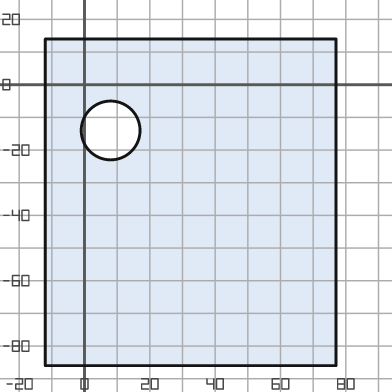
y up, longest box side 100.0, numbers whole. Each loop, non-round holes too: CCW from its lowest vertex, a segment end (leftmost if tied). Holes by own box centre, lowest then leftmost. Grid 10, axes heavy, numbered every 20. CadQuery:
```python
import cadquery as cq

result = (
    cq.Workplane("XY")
    .moveTo(-12.0, -86.0)
    .lineTo(77.0, -86.0)
    .lineTo(77.0, 14.0)
    .lineTo(-12.0, 14.0)
    .close()
    .moveTo(8.0, -14.0)
    .circle(9.0)
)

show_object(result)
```